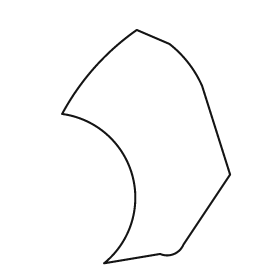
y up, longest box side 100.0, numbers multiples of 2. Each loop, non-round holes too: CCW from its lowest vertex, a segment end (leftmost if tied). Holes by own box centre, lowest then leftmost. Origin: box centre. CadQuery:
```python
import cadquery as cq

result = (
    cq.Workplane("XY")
    .moveTo(-18.0, -50.0)
    .lineTo(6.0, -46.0)
    .threePointArc((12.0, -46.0), (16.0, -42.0))
    .lineTo(36.0, -12.0)
    .lineTo(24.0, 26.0)
    .threePointArc((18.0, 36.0), (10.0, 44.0))
    .lineTo(-4.0, 50.0)
    .threePointArc((-22.0, 34.0), (-36.0, 14.0))
    .threePointArc((-6.0, -12.0), (-18.0, -50.0))
    .close()
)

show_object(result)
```